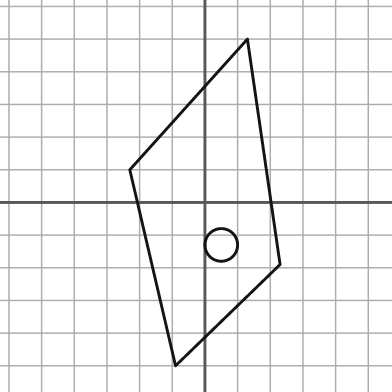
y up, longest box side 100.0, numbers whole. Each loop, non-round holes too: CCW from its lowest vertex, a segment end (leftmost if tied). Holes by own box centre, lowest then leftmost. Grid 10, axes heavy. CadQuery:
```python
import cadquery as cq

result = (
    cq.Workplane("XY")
    .moveTo(-9.0, -50.0)
    .lineTo(23.0, -19.0)
    .lineTo(13.0, 50.0)
    .lineTo(-23.0, 10.0)
    .close()
    .moveTo(5.0, -13.0)
    .circle(5.0)
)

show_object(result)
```